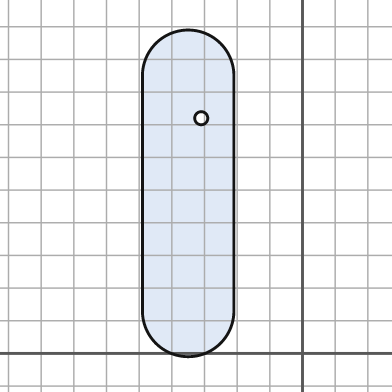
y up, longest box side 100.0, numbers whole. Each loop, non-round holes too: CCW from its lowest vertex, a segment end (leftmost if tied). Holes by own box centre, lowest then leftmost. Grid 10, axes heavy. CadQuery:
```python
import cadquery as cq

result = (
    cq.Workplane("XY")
    .moveTo(-49.0, 13.0)
    .threePointArc((-35.0, -1.0), (-21.0, 13.0))
    .lineTo(-21.0, 85.0)
    .threePointArc((-35.0, 99.0), (-49.0, 85.0))
    .close()
    .moveTo(-31.0, 72.0)
    .circle(2.0)
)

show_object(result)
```